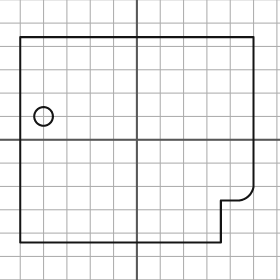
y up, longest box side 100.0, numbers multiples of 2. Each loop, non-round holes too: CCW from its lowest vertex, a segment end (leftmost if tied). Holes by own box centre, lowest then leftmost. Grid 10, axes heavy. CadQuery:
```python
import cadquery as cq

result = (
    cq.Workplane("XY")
    .moveTo(-50.0, -44.0)
    .lineTo(36.0, -44.0)
    .lineTo(36.0, -26.0)
    .lineTo(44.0, -26.0)
    .threePointArc((48.0, -24.0), (50.0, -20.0))
    .lineTo(50.0, 44.0)
    .lineTo(-50.0, 44.0)
    .close()
    .moveTo(-40.0, 10.0)
    .circle(4.0)
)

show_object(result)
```